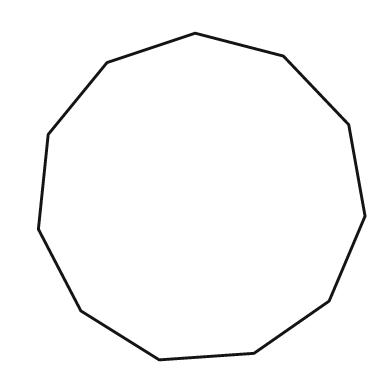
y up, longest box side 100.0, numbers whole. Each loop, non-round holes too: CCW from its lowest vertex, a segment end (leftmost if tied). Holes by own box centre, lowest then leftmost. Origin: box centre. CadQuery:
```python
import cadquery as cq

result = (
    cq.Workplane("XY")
    .moveTo(-13.0, -50.0)
    .lineTo(16.0, -48.0)
    .lineTo(39.0, -32.0)
    .lineTo(50.0, -6.0)
    .lineTo(45.0, 22.0)
    .lineTo(25.0, 43.0)
    .lineTo(-2.0, 50.0)
    .lineTo(-29.0, 41.0)
    .lineTo(-47.0, 19.0)
    .lineTo(-50.0, -10.0)
    .lineTo(-37.0, -35.0)
    .close()
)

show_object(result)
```